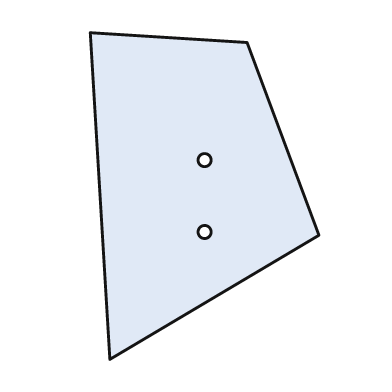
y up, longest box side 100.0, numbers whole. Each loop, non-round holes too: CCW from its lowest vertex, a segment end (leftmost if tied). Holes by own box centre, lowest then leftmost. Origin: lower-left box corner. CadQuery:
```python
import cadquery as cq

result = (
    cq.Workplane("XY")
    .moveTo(6.0, 0.0)
    .lineTo(70.0, 38.0)
    .lineTo(48.0, 97.0)
    .lineTo(0.0, 100.0)
    .close()
    .moveTo(35.0, 39.0)
    .circle(2.0)
    .moveTo(35.0, 61.0)
    .circle(2.0)
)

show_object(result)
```